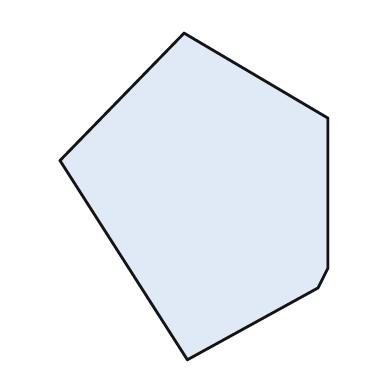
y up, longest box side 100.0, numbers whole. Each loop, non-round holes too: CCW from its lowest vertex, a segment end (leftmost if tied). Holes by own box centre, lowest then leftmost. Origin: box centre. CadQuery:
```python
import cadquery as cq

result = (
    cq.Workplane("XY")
    .moveTo(-2.0, -50.0)
    .lineTo(38.0, -28.0)
    .lineTo(41.0, -22.0)
    .lineTo(41.0, 24.0)
    .lineTo(-3.0, 50.0)
    .lineTo(-41.0, 11.0)
    .close()
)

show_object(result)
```